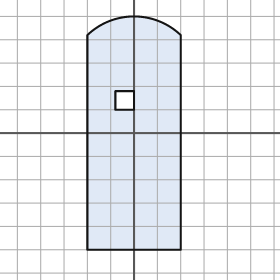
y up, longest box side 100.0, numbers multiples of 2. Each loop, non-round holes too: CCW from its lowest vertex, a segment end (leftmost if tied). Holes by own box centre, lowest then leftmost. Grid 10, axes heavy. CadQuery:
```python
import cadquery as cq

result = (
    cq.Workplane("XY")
    .moveTo(-20.0, -50.0)
    .lineTo(20.0, -50.0)
    .lineTo(20.0, 42.0)
    .threePointArc((0.0, 50.0), (-20.0, 42.0))
    .close()
    .moveTo(-8.0, 10.0)
    .lineTo(0.0, 10.0)
    .lineTo(0.0, 18.0)
    .lineTo(-8.0, 18.0)
    .close()
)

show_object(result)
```